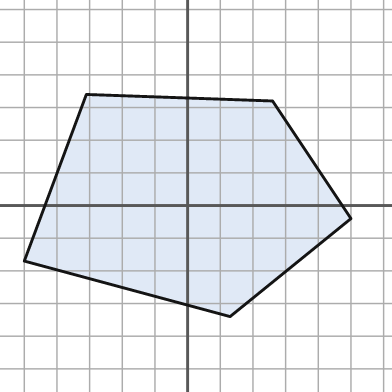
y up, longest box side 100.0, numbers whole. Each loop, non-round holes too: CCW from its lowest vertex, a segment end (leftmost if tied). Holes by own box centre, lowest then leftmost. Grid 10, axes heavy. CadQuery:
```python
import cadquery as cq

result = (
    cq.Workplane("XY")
    .moveTo(13.0, -34.0)
    .lineTo(50.0, -4.0)
    .lineTo(26.0, 32.0)
    .lineTo(-31.0, 34.0)
    .lineTo(-50.0, -17.0)
    .close()
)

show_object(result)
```